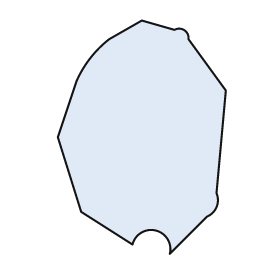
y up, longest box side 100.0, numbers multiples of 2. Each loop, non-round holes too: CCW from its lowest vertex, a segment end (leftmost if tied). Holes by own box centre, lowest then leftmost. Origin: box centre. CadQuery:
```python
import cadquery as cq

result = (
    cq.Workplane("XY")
    .moveTo(12.0, -50.0)
    .lineTo(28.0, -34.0)
    .threePointArc((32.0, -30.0), (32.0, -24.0))
    .lineTo(36.0, 20.0)
    .lineTo(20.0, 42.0)
    .threePointArc((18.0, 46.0), (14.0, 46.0))
    .lineTo(0.0, 50.0)
    .lineTo(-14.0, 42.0)
    .threePointArc((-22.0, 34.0), (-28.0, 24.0))
    .lineTo(-36.0, 0.0)
    .lineTo(-26.0, -32.0)
    .lineTo(-4.0, -46.0)
    .threePointArc((6.0, -40.0), (12.0, -50.0))
    .close()
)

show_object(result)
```